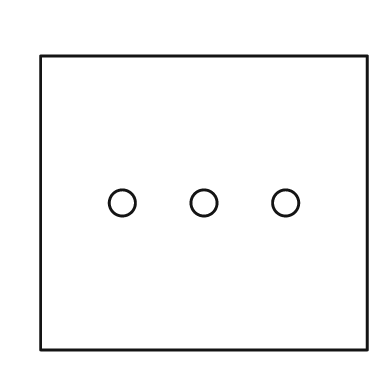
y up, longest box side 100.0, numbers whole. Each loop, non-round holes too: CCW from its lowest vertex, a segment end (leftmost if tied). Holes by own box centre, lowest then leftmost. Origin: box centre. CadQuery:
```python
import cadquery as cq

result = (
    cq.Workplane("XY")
    .moveTo(-50.0, -45.0)
    .lineTo(50.0, -45.0)
    .lineTo(50.0, 45.0)
    .lineTo(-50.0, 45.0)
    .close()
    .moveTo(-25.0, 0.0)
    .circle(4.0)
    .moveTo(0.0, 0.0)
    .circle(4.0)
    .moveTo(25.0, 0.0)
    .circle(4.0)
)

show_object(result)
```